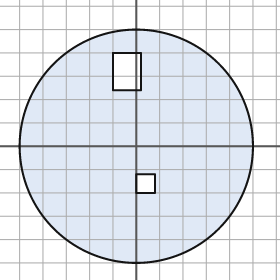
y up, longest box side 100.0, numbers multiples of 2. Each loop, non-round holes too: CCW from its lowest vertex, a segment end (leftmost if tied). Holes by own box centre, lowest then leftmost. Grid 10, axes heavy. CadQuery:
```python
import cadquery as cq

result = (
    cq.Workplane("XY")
    .moveTo(0.0, 0.0)
    .circle(50.0)
    .moveTo(0.0, -20.0)
    .lineTo(8.0, -20.0)
    .lineTo(8.0, -12.0)
    .lineTo(0.0, -12.0)
    .close()
    .moveTo(-10.0, 24.0)
    .lineTo(2.0, 24.0)
    .lineTo(2.0, 40.0)
    .lineTo(-10.0, 40.0)
    .close()
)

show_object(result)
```